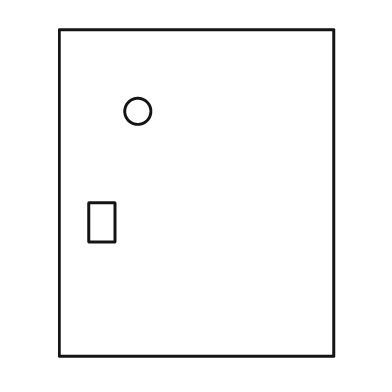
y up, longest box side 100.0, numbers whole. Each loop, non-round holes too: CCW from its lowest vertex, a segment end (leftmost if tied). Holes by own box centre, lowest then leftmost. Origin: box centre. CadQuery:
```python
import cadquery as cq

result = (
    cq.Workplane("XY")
    .moveTo(-42.0, -50.0)
    .lineTo(42.0, -50.0)
    .lineTo(42.0, 50.0)
    .lineTo(-42.0, 50.0)
    .close()
    .moveTo(-33.0, -15.0)
    .lineTo(-25.0, -15.0)
    .lineTo(-25.0, -3.0)
    .lineTo(-33.0, -3.0)
    .close()
    .moveTo(-18.0, 25.0)
    .circle(4.0)
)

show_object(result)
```